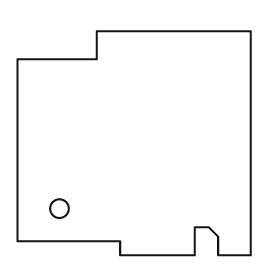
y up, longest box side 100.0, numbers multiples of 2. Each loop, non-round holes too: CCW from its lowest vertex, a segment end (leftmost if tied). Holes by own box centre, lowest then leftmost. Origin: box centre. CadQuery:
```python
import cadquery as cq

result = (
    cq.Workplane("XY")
    .moveTo(-6.0, -48.0)
    .lineTo(26.0, -48.0)
    .lineTo(26.0, -36.0)
    .lineTo(32.0, -36.0)
    .lineTo(36.0, -40.0)
    .lineTo(36.0, -48.0)
    .lineTo(50.0, -48.0)
    .lineTo(50.0, 48.0)
    .lineTo(-16.0, 48.0)
    .lineTo(-16.0, 36.0)
    .lineTo(-50.0, 36.0)
    .lineTo(-50.0, -42.0)
    .lineTo(-6.0, -42.0)
    .close()
    .moveTo(-32.0, -28.0)
    .circle(4.0)
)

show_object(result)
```